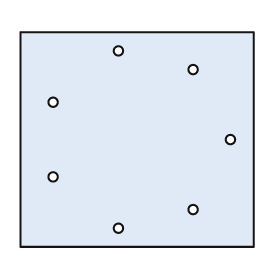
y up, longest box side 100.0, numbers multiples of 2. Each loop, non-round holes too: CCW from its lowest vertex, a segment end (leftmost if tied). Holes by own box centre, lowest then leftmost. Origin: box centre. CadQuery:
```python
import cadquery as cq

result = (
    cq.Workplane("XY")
    .moveTo(-50.0, -46.0)
    .lineTo(50.0, -46.0)
    .lineTo(50.0, 46.0)
    .lineTo(-50.0, 46.0)
    .close()
    .moveTo(-8.0, -38.0)
    .circle(2.0)
    .moveTo(24.0, -30.0)
    .circle(2.0)
    .moveTo(-36.0, -16.0)
    .circle(2.0)
    .moveTo(40.0, 0.0)
    .circle(2.0)
    .moveTo(-36.0, 16.0)
    .circle(2.0)
    .moveTo(24.0, 30.0)
    .circle(2.0)
    .moveTo(-8.0, 38.0)
    .circle(2.0)
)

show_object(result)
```